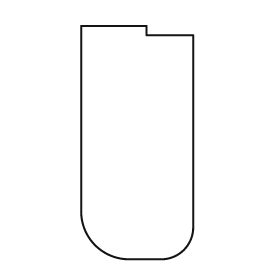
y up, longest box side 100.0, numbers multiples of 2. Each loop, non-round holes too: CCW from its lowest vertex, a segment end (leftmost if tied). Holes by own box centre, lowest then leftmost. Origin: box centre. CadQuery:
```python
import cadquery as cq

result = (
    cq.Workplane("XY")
    .moveTo(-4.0, -50.0)
    .lineTo(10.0, -50.0)
    .threePointArc((20.0, -46.0), (24.0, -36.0))
    .lineTo(24.0, 46.0)
    .lineTo(4.0, 46.0)
    .lineTo(4.0, 50.0)
    .lineTo(-24.0, 50.0)
    .lineTo(-24.0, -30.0)
    .threePointArc((-18.0, -44.0), (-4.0, -50.0))
    .close()
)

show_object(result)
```